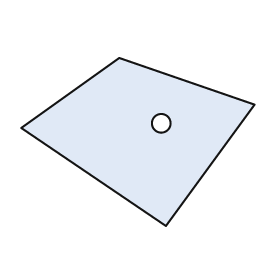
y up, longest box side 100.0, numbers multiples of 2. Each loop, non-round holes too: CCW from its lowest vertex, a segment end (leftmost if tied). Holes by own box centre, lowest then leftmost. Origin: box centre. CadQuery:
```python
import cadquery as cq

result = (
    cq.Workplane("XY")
    .moveTo(12.0, -36.0)
    .lineTo(50.0, 16.0)
    .lineTo(-8.0, 36.0)
    .lineTo(-50.0, 6.0)
    .close()
    .moveTo(10.0, 8.0)
    .circle(4.0)
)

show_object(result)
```